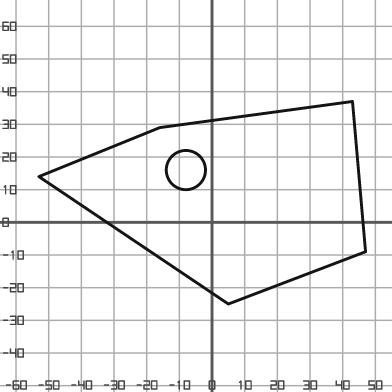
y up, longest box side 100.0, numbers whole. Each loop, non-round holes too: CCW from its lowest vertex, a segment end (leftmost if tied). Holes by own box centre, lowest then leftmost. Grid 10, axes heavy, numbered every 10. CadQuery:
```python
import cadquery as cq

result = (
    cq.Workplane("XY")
    .moveTo(5.0, -25.0)
    .lineTo(47.0, -9.0)
    .lineTo(43.0, 37.0)
    .lineTo(-16.0, 29.0)
    .lineTo(-53.0, 14.0)
    .close()
    .moveTo(-8.0, 16.0)
    .circle(6.0)
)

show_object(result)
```